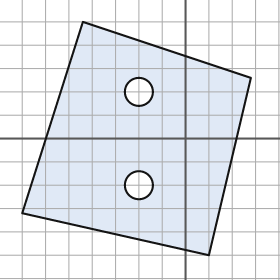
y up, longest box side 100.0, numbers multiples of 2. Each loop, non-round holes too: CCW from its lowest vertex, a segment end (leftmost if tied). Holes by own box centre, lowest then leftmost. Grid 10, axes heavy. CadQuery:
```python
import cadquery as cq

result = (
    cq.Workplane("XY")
    .moveTo(10.0, -50.0)
    .lineTo(28.0, 26.0)
    .lineTo(-44.0, 50.0)
    .lineTo(-70.0, -32.0)
    .close()
    .moveTo(-20.0, -20.0)
    .circle(6.0)
    .moveTo(-20.0, 20.0)
    .circle(6.0)
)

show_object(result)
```